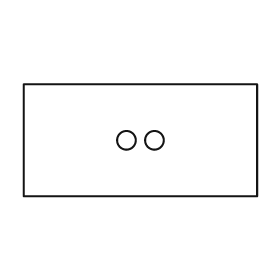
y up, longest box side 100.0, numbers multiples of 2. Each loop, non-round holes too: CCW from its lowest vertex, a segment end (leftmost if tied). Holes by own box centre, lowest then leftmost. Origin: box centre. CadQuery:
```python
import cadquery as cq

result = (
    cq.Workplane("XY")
    .moveTo(-50.0, -24.0)
    .lineTo(50.0, -24.0)
    .lineTo(50.0, 24.0)
    .lineTo(-50.0, 24.0)
    .close()
    .moveTo(-6.0, 0.0)
    .circle(4.0)
    .moveTo(6.0, 0.0)
    .circle(4.0)
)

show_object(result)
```